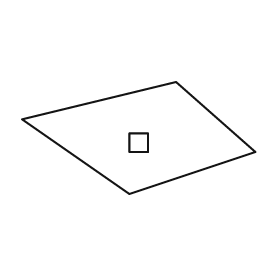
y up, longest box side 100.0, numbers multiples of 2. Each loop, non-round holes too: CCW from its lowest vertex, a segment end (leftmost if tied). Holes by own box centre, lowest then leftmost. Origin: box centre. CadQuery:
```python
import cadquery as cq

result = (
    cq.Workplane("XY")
    .moveTo(-4.0, -24.0)
    .lineTo(50.0, -6.0)
    .lineTo(16.0, 24.0)
    .lineTo(-50.0, 8.0)
    .close()
    .moveTo(-4.0, -6.0)
    .lineTo(4.0, -6.0)
    .lineTo(4.0, 2.0)
    .lineTo(-4.0, 2.0)
    .close()
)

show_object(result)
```